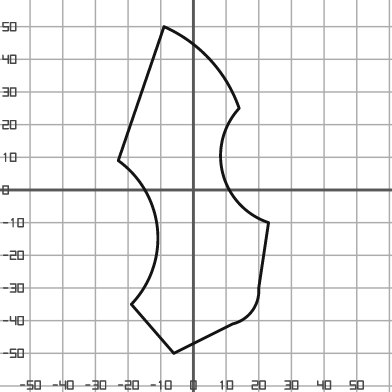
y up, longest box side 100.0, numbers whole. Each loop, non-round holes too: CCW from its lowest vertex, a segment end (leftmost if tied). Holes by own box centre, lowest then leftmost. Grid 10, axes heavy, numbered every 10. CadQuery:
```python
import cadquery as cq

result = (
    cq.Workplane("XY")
    .moveTo(-6.0, -50.0)
    .lineTo(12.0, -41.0)
    .threePointArc((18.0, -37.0), (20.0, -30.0))
    .lineTo(23.0, -10.0)
    .threePointArc((9.0, 5.0), (14.0, 25.0))
    .threePointArc((5.0, 40.0), (-9.0, 50.0))
    .lineTo(-23.0, 9.0)
    .threePointArc((-11.0, -12.0), (-19.0, -35.0))
    .close()
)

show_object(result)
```